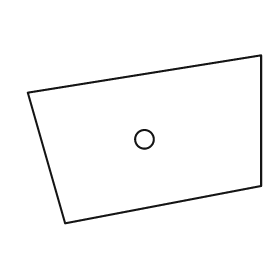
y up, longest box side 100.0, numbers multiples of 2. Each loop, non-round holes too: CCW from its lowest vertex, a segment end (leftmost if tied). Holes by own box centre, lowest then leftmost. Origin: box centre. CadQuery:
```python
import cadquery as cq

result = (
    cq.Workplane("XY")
    .moveTo(-34.0, -36.0)
    .lineTo(50.0, -20.0)
    .lineTo(50.0, 36.0)
    .lineTo(-50.0, 20.0)
    .close()
    .moveTo(0.0, 0.0)
    .circle(4.0)
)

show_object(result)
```